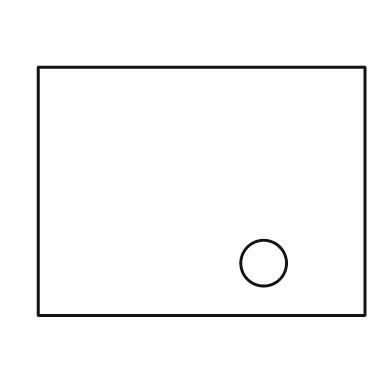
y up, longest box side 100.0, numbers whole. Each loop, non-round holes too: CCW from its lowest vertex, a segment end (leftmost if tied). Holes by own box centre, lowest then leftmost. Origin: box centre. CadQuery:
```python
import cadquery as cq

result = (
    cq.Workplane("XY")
    .moveTo(-50.0, -38.0)
    .lineTo(50.0, -38.0)
    .lineTo(50.0, 38.0)
    .lineTo(-50.0, 38.0)
    .close()
    .moveTo(19.0, -22.0)
    .circle(7.0)
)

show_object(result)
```